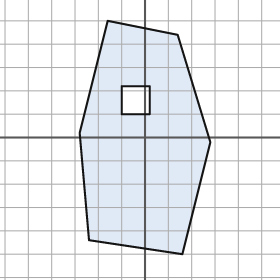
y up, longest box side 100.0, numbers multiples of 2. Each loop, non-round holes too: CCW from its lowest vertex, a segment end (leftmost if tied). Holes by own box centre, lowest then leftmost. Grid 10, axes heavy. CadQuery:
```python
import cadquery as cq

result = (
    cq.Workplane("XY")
    .moveTo(16.0, -50.0)
    .lineTo(28.0, -2.0)
    .lineTo(14.0, 44.0)
    .lineTo(-16.0, 50.0)
    .lineTo(-28.0, 2.0)
    .lineTo(-24.0, -44.0)
    .close()
    .moveTo(-10.0, 10.0)
    .lineTo(2.0, 10.0)
    .lineTo(2.0, 22.0)
    .lineTo(-10.0, 22.0)
    .close()
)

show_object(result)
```